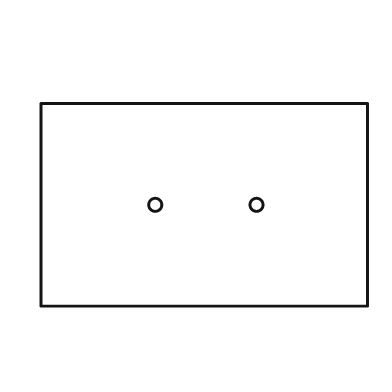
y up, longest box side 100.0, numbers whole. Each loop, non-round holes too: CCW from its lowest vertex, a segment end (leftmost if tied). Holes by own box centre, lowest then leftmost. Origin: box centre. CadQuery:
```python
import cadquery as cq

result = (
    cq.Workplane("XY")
    .moveTo(-50.0, -31.0)
    .lineTo(50.0, -31.0)
    .lineTo(50.0, 31.0)
    .lineTo(-50.0, 31.0)
    .close()
    .moveTo(-15.0, 0.0)
    .circle(2.0)
    .moveTo(16.0, 0.0)
    .circle(2.0)
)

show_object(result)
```